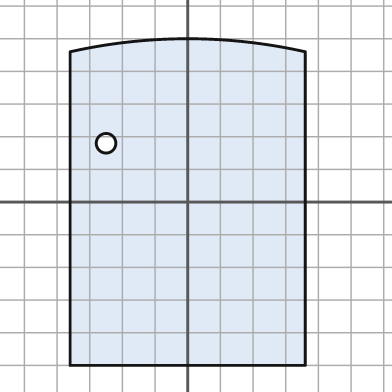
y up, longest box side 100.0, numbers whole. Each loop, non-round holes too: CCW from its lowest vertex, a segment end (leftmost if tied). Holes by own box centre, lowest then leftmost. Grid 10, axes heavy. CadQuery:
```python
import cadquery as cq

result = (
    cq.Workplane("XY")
    .moveTo(-36.0, -50.0)
    .lineTo(36.0, -50.0)
    .lineTo(36.0, 46.0)
    .threePointArc((0.0, 50.0), (-36.0, 46.0))
    .close()
    .moveTo(-25.0, 18.0)
    .circle(3.0)
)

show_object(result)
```